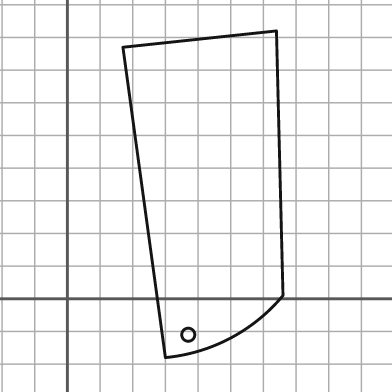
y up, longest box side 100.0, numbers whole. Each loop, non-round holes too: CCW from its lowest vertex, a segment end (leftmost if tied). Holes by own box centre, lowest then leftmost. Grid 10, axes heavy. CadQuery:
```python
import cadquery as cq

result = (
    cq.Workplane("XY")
    .moveTo(30.0, -18.0)
    .threePointArc((50.0, -12.0), (66.0, 1.0))
    .lineTo(64.0, 82.0)
    .lineTo(17.0, 77.0)
    .close()
    .moveTo(37.0, -11.0)
    .circle(2.0)
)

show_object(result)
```